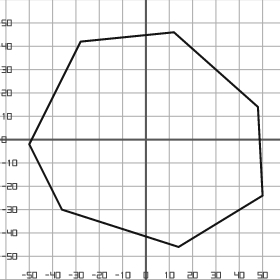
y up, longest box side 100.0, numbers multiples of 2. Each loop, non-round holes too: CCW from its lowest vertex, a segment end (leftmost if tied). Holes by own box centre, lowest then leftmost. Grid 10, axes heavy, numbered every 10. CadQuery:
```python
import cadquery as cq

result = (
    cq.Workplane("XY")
    .moveTo(14.0, -46.0)
    .lineTo(50.0, -24.0)
    .lineTo(48.0, 14.0)
    .lineTo(12.0, 46.0)
    .lineTo(-28.0, 42.0)
    .lineTo(-50.0, -2.0)
    .lineTo(-36.0, -30.0)
    .close()
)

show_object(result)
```